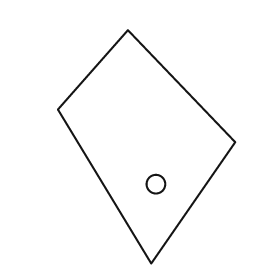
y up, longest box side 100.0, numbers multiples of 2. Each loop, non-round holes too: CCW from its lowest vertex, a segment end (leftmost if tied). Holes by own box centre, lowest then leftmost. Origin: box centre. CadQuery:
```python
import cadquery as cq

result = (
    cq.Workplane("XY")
    .moveTo(2.0, -50.0)
    .lineTo(38.0, 2.0)
    .lineTo(-8.0, 50.0)
    .lineTo(-38.0, 16.0)
    .close()
    .moveTo(4.0, -16.0)
    .circle(4.0)
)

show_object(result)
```